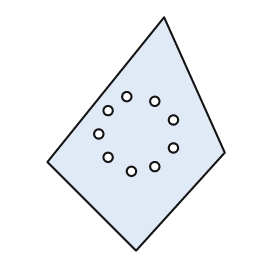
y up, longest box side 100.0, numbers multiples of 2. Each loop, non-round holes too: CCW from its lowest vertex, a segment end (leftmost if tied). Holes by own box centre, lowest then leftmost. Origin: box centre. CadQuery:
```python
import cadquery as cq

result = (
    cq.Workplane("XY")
    .moveTo(0.0, -50.0)
    .lineTo(38.0, -8.0)
    .lineTo(12.0, 50.0)
    .lineTo(-38.0, -12.0)
    .close()
    .moveTo(-2.0, -16.0)
    .circle(2.0)
    .moveTo(8.0, -14.0)
    .circle(2.0)
    .moveTo(-12.0, -10.0)
    .circle(2.0)
    .moveTo(16.0, -6.0)
    .circle(2.0)
    .moveTo(-16.0, 0.0)
    .circle(2.0)
    .moveTo(16.0, 6.0)
    .circle(2.0)
    .moveTo(-12.0, 10.0)
    .circle(2.0)
    .moveTo(8.0, 14.0)
    .circle(2.0)
    .moveTo(-4.0, 16.0)
    .circle(2.0)
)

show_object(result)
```